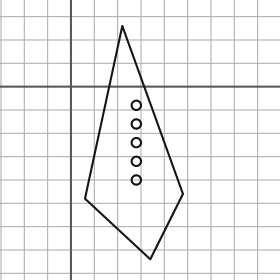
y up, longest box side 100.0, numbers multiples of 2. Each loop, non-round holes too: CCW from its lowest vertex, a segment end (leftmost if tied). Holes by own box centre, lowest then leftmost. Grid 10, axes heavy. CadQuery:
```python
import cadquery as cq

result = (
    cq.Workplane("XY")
    .moveTo(34.0, -74.0)
    .lineTo(48.0, -46.0)
    .lineTo(22.0, 26.0)
    .lineTo(6.0, -48.0)
    .close()
    .moveTo(28.0, -40.0)
    .circle(2.0)
    .moveTo(28.0, -32.0)
    .circle(2.0)
    .moveTo(28.0, -24.0)
    .circle(2.0)
    .moveTo(28.0, -16.0)
    .circle(2.0)
    .moveTo(28.0, -8.0)
    .circle(2.0)
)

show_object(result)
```